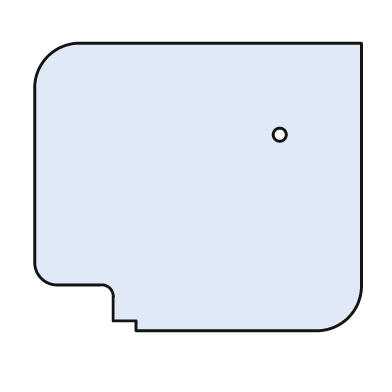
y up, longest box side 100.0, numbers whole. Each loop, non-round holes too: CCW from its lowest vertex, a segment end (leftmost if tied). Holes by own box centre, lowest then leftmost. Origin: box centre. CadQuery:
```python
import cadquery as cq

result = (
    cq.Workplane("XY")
    .moveTo(-19.0, -44.0)
    .lineTo(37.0, -44.0)
    .threePointArc((46.0, -40.0), (50.0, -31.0))
    .lineTo(50.0, 44.0)
    .lineTo(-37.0, 44.0)
    .threePointArc((-46.0, 40.0), (-50.0, 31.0))
    .lineTo(-50.0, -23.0)
    .threePointArc((-48.0, -28.0), (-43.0, -30.0))
    .lineTo(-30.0, -30.0)
    .threePointArc((-27.0, -31.0), (-26.0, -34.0))
    .lineTo(-26.0, -41.0)
    .lineTo(-19.0, -41.0)
    .close()
    .moveTo(25.0, 16.0)
    .circle(2.0)
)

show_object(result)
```